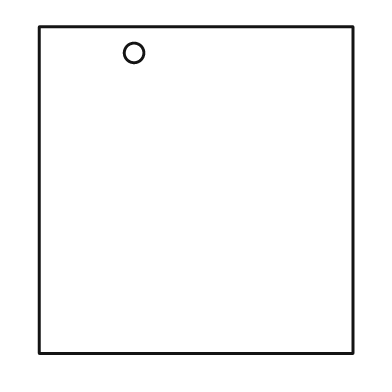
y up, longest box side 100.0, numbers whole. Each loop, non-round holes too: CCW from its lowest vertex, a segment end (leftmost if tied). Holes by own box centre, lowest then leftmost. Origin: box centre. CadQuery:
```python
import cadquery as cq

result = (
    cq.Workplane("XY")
    .moveTo(-48.0, -50.0)
    .lineTo(48.0, -50.0)
    .lineTo(48.0, 50.0)
    .lineTo(-48.0, 50.0)
    .close()
    .moveTo(-19.0, 42.0)
    .circle(3.0)
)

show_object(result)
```